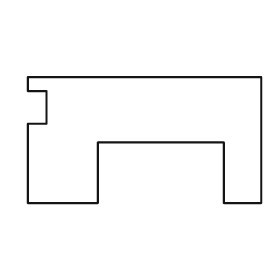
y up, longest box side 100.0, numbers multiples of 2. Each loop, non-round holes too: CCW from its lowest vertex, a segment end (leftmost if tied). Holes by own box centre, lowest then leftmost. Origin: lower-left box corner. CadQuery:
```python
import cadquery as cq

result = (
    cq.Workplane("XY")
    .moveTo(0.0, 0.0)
    .lineTo(30.0, 0.0)
    .lineTo(30.0, 26.0)
    .lineTo(84.0, 26.0)
    .lineTo(84.0, 0.0)
    .lineTo(100.0, 0.0)
    .lineTo(100.0, 54.0)
    .lineTo(0.0, 54.0)
    .lineTo(0.0, 48.0)
    .lineTo(8.0, 48.0)
    .lineTo(8.0, 34.0)
    .lineTo(0.0, 34.0)
    .close()
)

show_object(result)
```